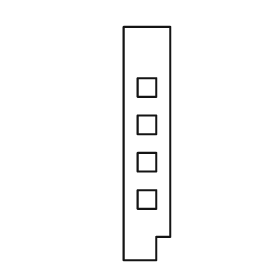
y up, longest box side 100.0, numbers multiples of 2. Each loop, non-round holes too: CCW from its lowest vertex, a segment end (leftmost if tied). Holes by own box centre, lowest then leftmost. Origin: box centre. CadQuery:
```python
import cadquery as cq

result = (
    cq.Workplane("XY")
    .moveTo(-10.0, -50.0)
    .lineTo(4.0, -50.0)
    .lineTo(4.0, -40.0)
    .lineTo(10.0, -40.0)
    .lineTo(10.0, 50.0)
    .lineTo(-10.0, 50.0)
    .close()
    .moveTo(-4.0, -28.0)
    .lineTo(4.0, -28.0)
    .lineTo(4.0, -20.0)
    .lineTo(-4.0, -20.0)
    .close()
    .moveTo(-4.0, -12.0)
    .lineTo(4.0, -12.0)
    .lineTo(4.0, -4.0)
    .lineTo(-4.0, -4.0)
    .close()
    .moveTo(-4.0, 4.0)
    .lineTo(4.0, 4.0)
    .lineTo(4.0, 12.0)
    .lineTo(-4.0, 12.0)
    .close()
    .moveTo(-4.0, 20.0)
    .lineTo(4.0, 20.0)
    .lineTo(4.0, 28.0)
    .lineTo(-4.0, 28.0)
    .close()
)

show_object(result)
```